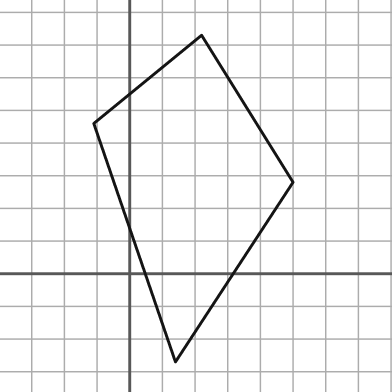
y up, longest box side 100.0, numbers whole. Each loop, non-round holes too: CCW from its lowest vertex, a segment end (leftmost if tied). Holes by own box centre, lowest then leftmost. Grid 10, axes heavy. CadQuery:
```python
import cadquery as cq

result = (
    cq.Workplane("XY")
    .moveTo(14.0, -27.0)
    .lineTo(50.0, 28.0)
    .lineTo(22.0, 73.0)
    .lineTo(-11.0, 46.0)
    .close()
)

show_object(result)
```